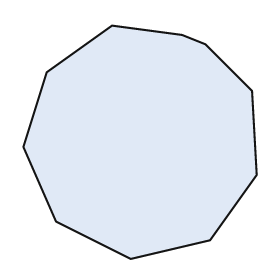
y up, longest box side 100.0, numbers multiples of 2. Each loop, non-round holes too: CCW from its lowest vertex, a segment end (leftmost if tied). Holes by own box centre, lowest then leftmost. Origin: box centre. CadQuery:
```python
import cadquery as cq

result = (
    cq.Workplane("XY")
    .moveTo(-4.0, -50.0)
    .lineTo(30.0, -42.0)
    .lineTo(50.0, -14.0)
    .lineTo(48.0, 22.0)
    .lineTo(28.0, 42.0)
    .lineTo(18.0, 46.0)
    .lineTo(-12.0, 50.0)
    .lineTo(-40.0, 30.0)
    .lineTo(-50.0, -2.0)
    .lineTo(-36.0, -34.0)
    .close()
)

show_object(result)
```